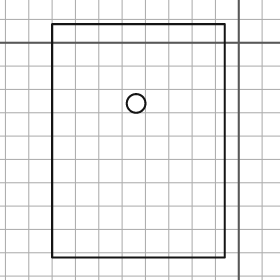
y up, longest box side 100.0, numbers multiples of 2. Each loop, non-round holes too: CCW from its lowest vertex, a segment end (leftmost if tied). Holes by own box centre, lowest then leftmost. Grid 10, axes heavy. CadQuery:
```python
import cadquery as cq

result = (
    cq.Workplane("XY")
    .moveTo(-80.0, -92.0)
    .lineTo(-6.0, -92.0)
    .lineTo(-6.0, 8.0)
    .lineTo(-80.0, 8.0)
    .close()
    .moveTo(-44.0, -26.0)
    .circle(4.0)
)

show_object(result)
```